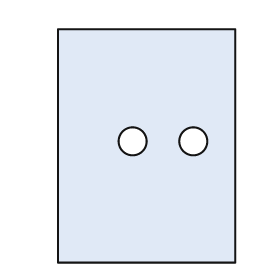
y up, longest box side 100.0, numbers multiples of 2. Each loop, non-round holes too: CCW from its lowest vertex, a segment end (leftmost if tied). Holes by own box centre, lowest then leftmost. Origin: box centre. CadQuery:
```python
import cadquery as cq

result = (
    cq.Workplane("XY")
    .moveTo(-38.0, -50.0)
    .lineTo(38.0, -50.0)
    .lineTo(38.0, 50.0)
    .lineTo(-38.0, 50.0)
    .close()
    .moveTo(-6.0, 2.0)
    .circle(6.0)
    .moveTo(20.0, 2.0)
    .circle(6.0)
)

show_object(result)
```